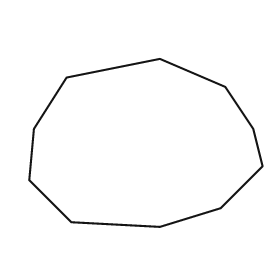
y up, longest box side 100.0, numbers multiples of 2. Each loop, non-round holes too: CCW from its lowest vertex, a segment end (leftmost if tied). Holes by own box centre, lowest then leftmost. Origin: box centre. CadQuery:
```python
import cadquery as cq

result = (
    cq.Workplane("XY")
    .moveTo(6.0, -36.0)
    .lineTo(32.0, -28.0)
    .lineTo(50.0, -10.0)
    .lineTo(46.0, 6.0)
    .lineTo(34.0, 24.0)
    .lineTo(6.0, 36.0)
    .lineTo(-34.0, 28.0)
    .lineTo(-48.0, 6.0)
    .lineTo(-50.0, -16.0)
    .lineTo(-32.0, -34.0)
    .close()
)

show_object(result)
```